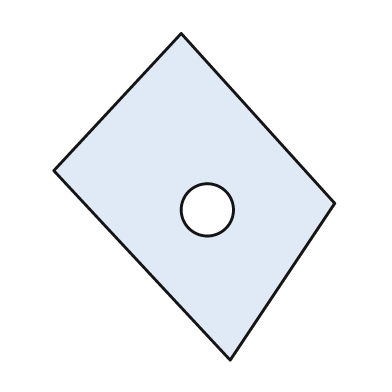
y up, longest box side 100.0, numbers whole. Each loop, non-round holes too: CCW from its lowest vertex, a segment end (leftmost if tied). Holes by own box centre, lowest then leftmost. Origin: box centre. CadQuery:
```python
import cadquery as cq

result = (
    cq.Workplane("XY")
    .moveTo(11.0, -50.0)
    .lineTo(43.0, -2.0)
    .lineTo(-4.0, 50.0)
    .lineTo(-43.0, 8.0)
    .close()
    .moveTo(4.0, -4.0)
    .circle(8.0)
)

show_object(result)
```